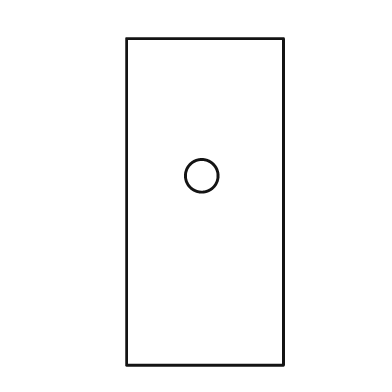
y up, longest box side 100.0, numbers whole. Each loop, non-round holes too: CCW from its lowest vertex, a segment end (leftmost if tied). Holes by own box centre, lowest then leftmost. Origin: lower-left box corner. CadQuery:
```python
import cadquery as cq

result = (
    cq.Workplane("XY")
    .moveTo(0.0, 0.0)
    .lineTo(48.0, 0.0)
    .lineTo(48.0, 100.0)
    .lineTo(0.0, 100.0)
    .close()
    .moveTo(23.0, 58.0)
    .circle(5.0)
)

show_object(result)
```